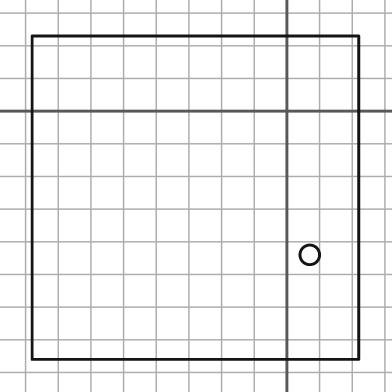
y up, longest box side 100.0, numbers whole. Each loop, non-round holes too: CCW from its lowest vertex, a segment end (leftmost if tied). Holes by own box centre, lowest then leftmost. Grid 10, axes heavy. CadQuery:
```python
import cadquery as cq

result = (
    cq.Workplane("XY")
    .moveTo(-78.0, -76.0)
    .lineTo(22.0, -76.0)
    .lineTo(22.0, 23.0)
    .lineTo(-78.0, 23.0)
    .close()
    .moveTo(7.0, -44.0)
    .circle(3.0)
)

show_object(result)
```